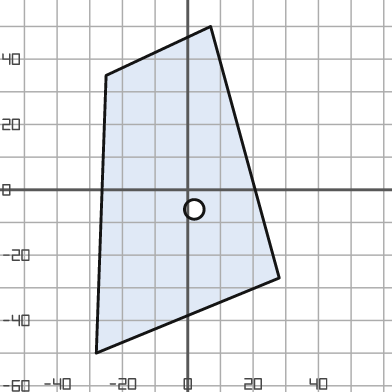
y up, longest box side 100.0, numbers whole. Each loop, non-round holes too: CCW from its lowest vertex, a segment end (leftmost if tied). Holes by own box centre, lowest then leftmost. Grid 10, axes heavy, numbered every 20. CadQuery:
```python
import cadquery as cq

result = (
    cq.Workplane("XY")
    .moveTo(-28.0, -50.0)
    .lineTo(28.0, -27.0)
    .lineTo(7.0, 50.0)
    .lineTo(-25.0, 35.0)
    .close()
    .moveTo(2.0, -6.0)
    .circle(3.0)
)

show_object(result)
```